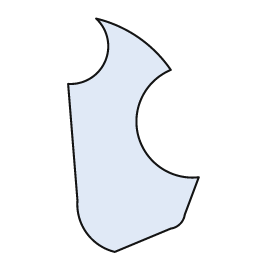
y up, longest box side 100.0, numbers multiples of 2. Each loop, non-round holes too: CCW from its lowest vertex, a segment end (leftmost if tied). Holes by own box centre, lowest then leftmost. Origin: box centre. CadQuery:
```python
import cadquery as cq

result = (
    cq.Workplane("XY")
    .moveTo(-8.0, -50.0)
    .lineTo(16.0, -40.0)
    .threePointArc((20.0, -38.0), (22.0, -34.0))
    .lineTo(28.0, -18.0)
    .threePointArc((2.0, 0.0), (16.0, 28.0))
    .threePointArc((2.0, 42.0), (-16.0, 50.0))
    .threePointArc((-12.0, 32.0), (-28.0, 22.0))
    .lineTo(-24.0, -28.0)
    .threePointArc((-20.0, -42.0), (-8.0, -50.0))
    .close()
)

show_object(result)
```